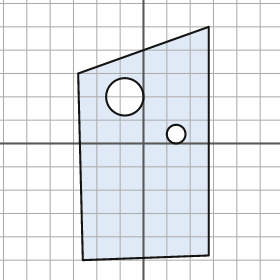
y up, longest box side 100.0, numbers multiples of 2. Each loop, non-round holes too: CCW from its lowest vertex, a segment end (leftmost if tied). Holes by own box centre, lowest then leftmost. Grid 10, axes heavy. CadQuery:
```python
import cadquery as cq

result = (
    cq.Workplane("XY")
    .moveTo(-26.0, -50.0)
    .lineTo(28.0, -48.0)
    .lineTo(28.0, 50.0)
    .lineTo(-28.0, 30.0)
    .close()
    .moveTo(14.0, 4.0)
    .circle(4.0)
    .moveTo(-8.0, 20.0)
    .circle(8.0)
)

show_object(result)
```